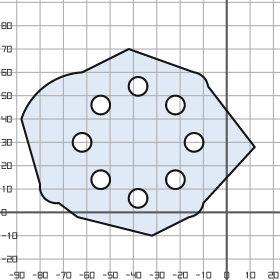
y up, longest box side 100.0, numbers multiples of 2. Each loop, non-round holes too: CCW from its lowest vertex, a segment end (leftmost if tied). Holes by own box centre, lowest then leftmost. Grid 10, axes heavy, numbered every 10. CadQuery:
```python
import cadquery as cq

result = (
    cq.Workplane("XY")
    .moveTo(-32.0, -10.0)
    .lineTo(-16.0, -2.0)
    .threePointArc((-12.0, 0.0), (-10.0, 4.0))
    .lineTo(12.0, 28.0)
    .lineTo(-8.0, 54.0)
    .threePointArc((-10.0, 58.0), (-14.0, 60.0))
    .lineTo(-42.0, 70.0)
    .lineTo(-62.0, 60.0)
    .threePointArc((-78.0, 54.0), (-88.0, 40.0))
    .lineTo(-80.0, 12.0)
    .threePointArc((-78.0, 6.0), (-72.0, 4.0))
    .lineTo(-64.0, -2.0)
    .close()
    .moveTo(-38.0, 6.0)
    .circle(4.0)
    .moveTo(-54.0, 14.0)
    .circle(4.0)
    .moveTo(-22.0, 14.0)
    .circle(4.0)
    .moveTo(-62.0, 30.0)
    .circle(4.0)
    .moveTo(-14.0, 30.0)
    .circle(4.0)
    .moveTo(-54.0, 46.0)
    .circle(4.0)
    .moveTo(-22.0, 46.0)
    .circle(4.0)
    .moveTo(-38.0, 54.0)
    .circle(4.0)
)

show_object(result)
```